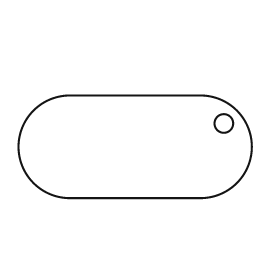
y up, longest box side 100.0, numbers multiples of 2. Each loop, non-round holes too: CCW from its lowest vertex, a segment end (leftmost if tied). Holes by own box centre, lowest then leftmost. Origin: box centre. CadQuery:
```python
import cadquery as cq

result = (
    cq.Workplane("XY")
    .moveTo(-28.0, -22.0)
    .lineTo(28.0, -22.0)
    .threePointArc((50.0, 0.0), (28.0, 22.0))
    .lineTo(-28.0, 22.0)
    .threePointArc((-50.0, 0.0), (-28.0, -22.0))
    .close()
    .moveTo(38.0, 10.0)
    .circle(4.0)
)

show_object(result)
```